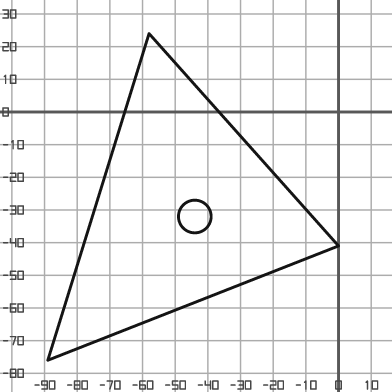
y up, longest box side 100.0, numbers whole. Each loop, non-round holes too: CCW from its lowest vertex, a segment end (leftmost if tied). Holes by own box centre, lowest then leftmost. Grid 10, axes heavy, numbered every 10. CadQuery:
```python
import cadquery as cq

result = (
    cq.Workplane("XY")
    .moveTo(-89.0, -76.0)
    .lineTo(0.0, -41.0)
    .lineTo(-58.0, 24.0)
    .close()
    .moveTo(-44.0, -32.0)
    .circle(5.0)
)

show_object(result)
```